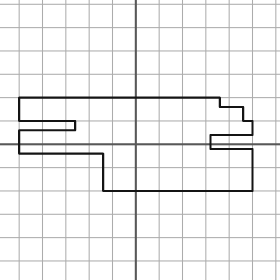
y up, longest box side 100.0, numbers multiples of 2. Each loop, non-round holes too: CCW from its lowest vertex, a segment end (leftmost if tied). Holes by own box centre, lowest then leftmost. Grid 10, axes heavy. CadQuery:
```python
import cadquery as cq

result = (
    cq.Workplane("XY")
    .moveTo(-14.0, -20.0)
    .lineTo(50.0, -20.0)
    .lineTo(50.0, -2.0)
    .lineTo(32.0, -2.0)
    .lineTo(32.0, 4.0)
    .lineTo(50.0, 4.0)
    .lineTo(50.0, 10.0)
    .lineTo(46.0, 10.0)
    .lineTo(46.0, 16.0)
    .lineTo(36.0, 16.0)
    .lineTo(36.0, 20.0)
    .lineTo(-50.0, 20.0)
    .lineTo(-50.0, 10.0)
    .lineTo(-26.0, 10.0)
    .lineTo(-26.0, 6.0)
    .lineTo(-50.0, 6.0)
    .lineTo(-50.0, -4.0)
    .lineTo(-14.0, -4.0)
    .close()
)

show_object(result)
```